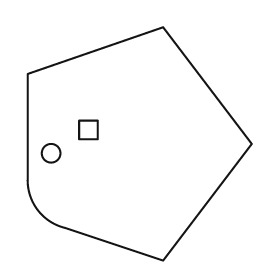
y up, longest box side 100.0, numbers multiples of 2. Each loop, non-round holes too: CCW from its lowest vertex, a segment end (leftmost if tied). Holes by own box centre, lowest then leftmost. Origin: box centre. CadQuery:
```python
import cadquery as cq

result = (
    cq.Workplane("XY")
    .moveTo(10.0, -50.0)
    .lineTo(48.0, 0.0)
    .lineTo(10.0, 50.0)
    .lineTo(-48.0, 30.0)
    .lineTo(-48.0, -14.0)
    .threePointArc((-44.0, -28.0), (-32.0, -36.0))
    .close()
    .moveTo(-38.0, -4.0)
    .circle(4.0)
    .moveTo(-26.0, 2.0)
    .lineTo(-18.0, 2.0)
    .lineTo(-18.0, 10.0)
    .lineTo(-26.0, 10.0)
    .close()
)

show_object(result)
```